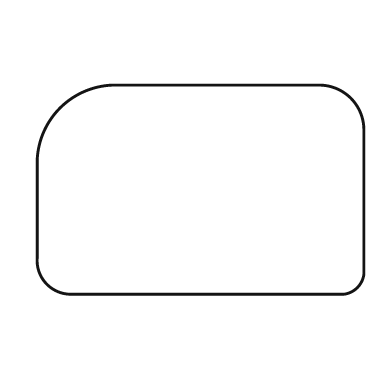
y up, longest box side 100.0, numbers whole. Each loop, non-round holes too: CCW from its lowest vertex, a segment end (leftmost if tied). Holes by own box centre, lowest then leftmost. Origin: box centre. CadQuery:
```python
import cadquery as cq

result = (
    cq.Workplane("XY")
    .moveTo(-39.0, -32.0)
    .lineTo(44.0, -32.0)
    .threePointArc((48.0, -30.0), (50.0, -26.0))
    .lineTo(50.0, 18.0)
    .threePointArc((46.0, 28.0), (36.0, 32.0))
    .lineTo(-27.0, 32.0)
    .threePointArc((-43.0, 25.0), (-50.0, 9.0))
    .lineTo(-50.0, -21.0)
    .threePointArc((-47.0, -29.0), (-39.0, -32.0))
    .close()
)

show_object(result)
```